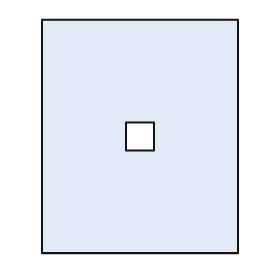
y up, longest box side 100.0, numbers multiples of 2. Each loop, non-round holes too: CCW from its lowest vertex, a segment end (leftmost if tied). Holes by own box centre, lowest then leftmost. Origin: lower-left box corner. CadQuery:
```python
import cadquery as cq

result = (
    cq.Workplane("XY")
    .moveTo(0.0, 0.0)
    .lineTo(84.0, 0.0)
    .lineTo(84.0, 100.0)
    .lineTo(0.0, 100.0)
    .close()
    .moveTo(36.0, 44.0)
    .lineTo(48.0, 44.0)
    .lineTo(48.0, 56.0)
    .lineTo(36.0, 56.0)
    .close()
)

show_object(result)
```